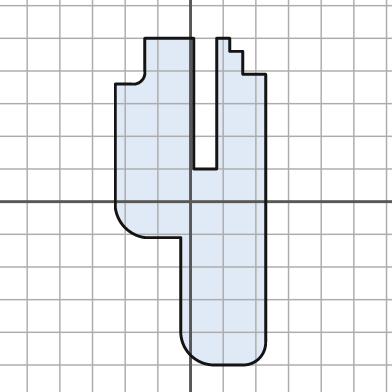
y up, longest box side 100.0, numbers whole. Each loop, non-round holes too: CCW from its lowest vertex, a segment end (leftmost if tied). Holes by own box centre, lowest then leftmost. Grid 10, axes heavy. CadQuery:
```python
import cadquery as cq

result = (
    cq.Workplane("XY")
    .moveTo(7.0, -50.0)
    .lineTo(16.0, -50.0)
    .threePointArc((21.0, -48.0), (23.0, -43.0))
    .lineTo(23.0, 39.0)
    .lineTo(16.0, 39.0)
    .lineTo(16.0, 46.0)
    .lineTo(12.0, 46.0)
    .lineTo(12.0, 50.0)
    .lineTo(8.0, 50.0)
    .lineTo(8.0, 10.0)
    .lineTo(1.0, 10.0)
    .lineTo(1.0, 50.0)
    .lineTo(-14.0, 50.0)
    .lineTo(-14.0, 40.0)
    .threePointArc((-15.0, 37.0), (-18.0, 36.0))
    .lineTo(-23.0, 36.0)
    .lineTo(-23.0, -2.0)
    .threePointArc((-20.0, -8.0), (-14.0, -11.0))
    .lineTo(-3.0, -11.0)
    .lineTo(-3.0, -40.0)
    .threePointArc((0.0, -47.0), (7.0, -50.0))
    .close()
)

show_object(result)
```